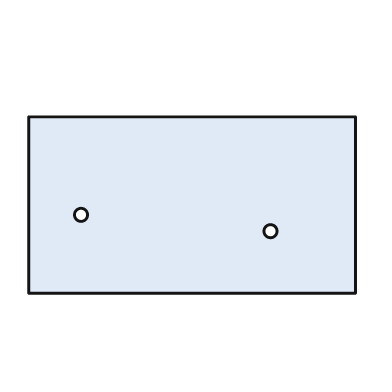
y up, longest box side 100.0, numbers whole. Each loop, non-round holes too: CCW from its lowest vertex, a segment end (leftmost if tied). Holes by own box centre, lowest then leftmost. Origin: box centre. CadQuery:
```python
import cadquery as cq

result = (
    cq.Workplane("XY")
    .moveTo(-50.0, -27.0)
    .lineTo(50.0, -27.0)
    .lineTo(50.0, 27.0)
    .lineTo(-50.0, 27.0)
    .close()
    .moveTo(24.0, -8.0)
    .circle(2.0)
    .moveTo(-34.0, -3.0)
    .circle(2.0)
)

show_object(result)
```